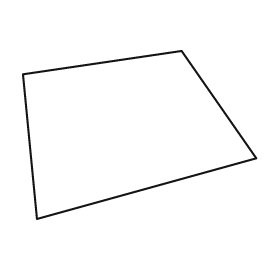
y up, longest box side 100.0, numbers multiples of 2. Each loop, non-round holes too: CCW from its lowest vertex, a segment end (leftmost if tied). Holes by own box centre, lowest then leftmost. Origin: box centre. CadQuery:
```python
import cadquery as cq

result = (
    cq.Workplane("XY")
    .moveTo(-44.0, -36.0)
    .lineTo(50.0, -10.0)
    .lineTo(18.0, 36.0)
    .lineTo(-50.0, 26.0)
    .close()
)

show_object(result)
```